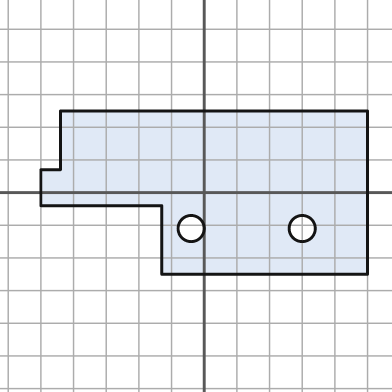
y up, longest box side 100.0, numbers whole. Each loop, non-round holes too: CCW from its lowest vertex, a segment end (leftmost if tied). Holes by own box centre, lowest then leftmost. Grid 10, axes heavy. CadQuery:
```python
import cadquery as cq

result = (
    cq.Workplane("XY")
    .moveTo(-13.0, -25.0)
    .lineTo(50.0, -25.0)
    .lineTo(50.0, 25.0)
    .lineTo(-44.0, 25.0)
    .lineTo(-44.0, 7.0)
    .lineTo(-50.0, 7.0)
    .lineTo(-50.0, -4.0)
    .lineTo(-13.0, -4.0)
    .close()
    .moveTo(-4.0, -11.0)
    .circle(4.0)
    .moveTo(30.0, -11.0)
    .circle(4.0)
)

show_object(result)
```